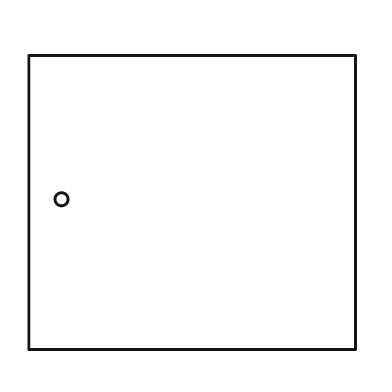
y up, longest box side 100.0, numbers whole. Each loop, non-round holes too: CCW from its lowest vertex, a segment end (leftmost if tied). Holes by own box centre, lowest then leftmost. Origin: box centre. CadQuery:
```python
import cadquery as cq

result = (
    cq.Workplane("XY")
    .moveTo(-50.0, -45.0)
    .lineTo(50.0, -45.0)
    .lineTo(50.0, 45.0)
    .lineTo(-50.0, 45.0)
    .close()
    .moveTo(-40.0, 1.0)
    .circle(2.0)
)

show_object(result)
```